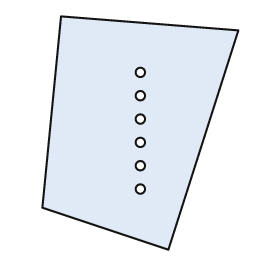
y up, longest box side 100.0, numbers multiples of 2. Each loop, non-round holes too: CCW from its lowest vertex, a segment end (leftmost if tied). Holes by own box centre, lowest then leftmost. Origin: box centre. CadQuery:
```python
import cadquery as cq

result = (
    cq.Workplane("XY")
    .moveTo(12.0, -50.0)
    .lineTo(42.0, 44.0)
    .lineTo(-34.0, 50.0)
    .lineTo(-42.0, -32.0)
    .close()
    .moveTo(0.0, -24.0)
    .circle(2.0)
    .moveTo(0.0, -14.0)
    .circle(2.0)
    .moveTo(0.0, -4.0)
    .circle(2.0)
    .moveTo(0.0, 6.0)
    .circle(2.0)
    .moveTo(0.0, 16.0)
    .circle(2.0)
    .moveTo(0.0, 26.0)
    .circle(2.0)
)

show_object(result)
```